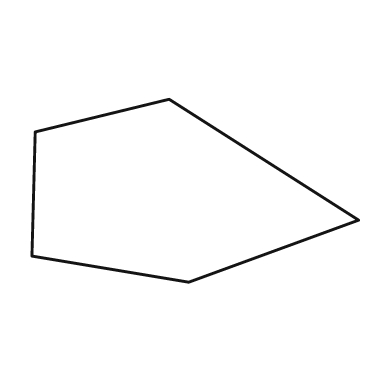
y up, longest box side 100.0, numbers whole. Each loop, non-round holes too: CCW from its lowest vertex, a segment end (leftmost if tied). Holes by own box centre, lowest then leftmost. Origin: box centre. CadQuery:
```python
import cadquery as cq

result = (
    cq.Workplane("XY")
    .moveTo(-2.0, -28.0)
    .lineTo(50.0, -9.0)
    .lineTo(-8.0, 28.0)
    .lineTo(-49.0, 18.0)
    .lineTo(-50.0, -20.0)
    .close()
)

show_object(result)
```